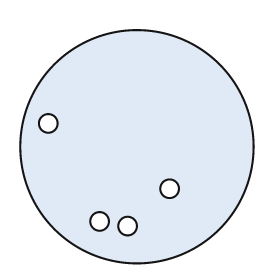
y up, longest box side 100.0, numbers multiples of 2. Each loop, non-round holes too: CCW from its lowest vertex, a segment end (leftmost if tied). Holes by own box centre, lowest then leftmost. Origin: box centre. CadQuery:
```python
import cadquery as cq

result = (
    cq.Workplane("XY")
    .moveTo(0.0, 0.0)
    .circle(50.0)
    .moveTo(-4.0, -34.0)
    .circle(4.0)
    .moveTo(-16.0, -32.0)
    .circle(4.0)
    .moveTo(14.0, -18.0)
    .circle(4.0)
    .moveTo(-38.0, 10.0)
    .circle(4.0)
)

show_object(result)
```